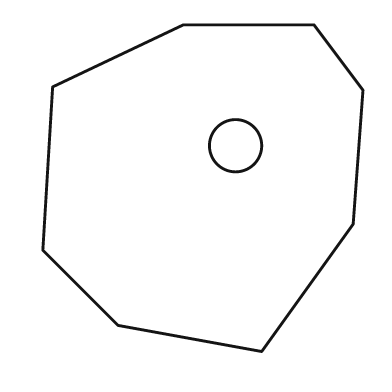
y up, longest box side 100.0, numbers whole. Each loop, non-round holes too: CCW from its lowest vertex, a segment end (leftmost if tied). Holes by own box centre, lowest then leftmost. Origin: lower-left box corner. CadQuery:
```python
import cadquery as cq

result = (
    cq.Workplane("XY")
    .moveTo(67.0, 0.0)
    .lineTo(95.0, 39.0)
    .lineTo(98.0, 80.0)
    .lineTo(83.0, 100.0)
    .lineTo(43.0, 100.0)
    .lineTo(3.0, 81.0)
    .lineTo(0.0, 31.0)
    .lineTo(23.0, 8.0)
    .close()
    .moveTo(59.0, 63.0)
    .circle(8.0)
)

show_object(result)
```